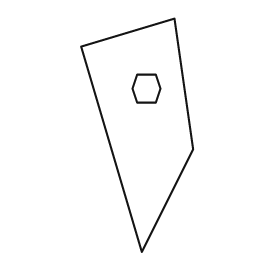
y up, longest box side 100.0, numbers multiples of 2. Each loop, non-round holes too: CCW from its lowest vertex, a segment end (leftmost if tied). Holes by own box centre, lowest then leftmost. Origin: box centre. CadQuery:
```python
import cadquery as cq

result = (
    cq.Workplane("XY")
    .moveTo(2.0, -50.0)
    .lineTo(24.0, -6.0)
    .lineTo(16.0, 50.0)
    .lineTo(-24.0, 38.0)
    .close()
    .moveTo(0.0, 14.0)
    .lineTo(8.0, 14.0)
    .lineTo(10.0, 20.0)
    .lineTo(8.0, 26.0)
    .lineTo(0.0, 26.0)
    .lineTo(-2.0, 20.0)
    .close()
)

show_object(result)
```